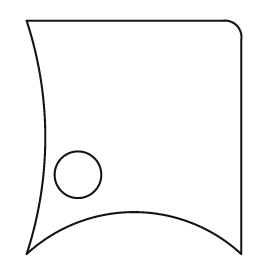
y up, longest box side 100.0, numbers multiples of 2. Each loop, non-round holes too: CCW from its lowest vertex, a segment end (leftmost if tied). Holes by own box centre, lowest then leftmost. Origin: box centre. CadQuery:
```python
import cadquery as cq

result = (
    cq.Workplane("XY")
    .moveTo(-46.0, -50.0)
    .threePointArc((0.0, -32.0), (46.0, -50.0))
    .lineTo(46.0, 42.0)
    .threePointArc((44.0, 48.0), (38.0, 50.0))
    .lineTo(-46.0, 50.0)
    .threePointArc((-38.0, 0.0), (-46.0, -50.0))
    .close()
    .moveTo(-24.0, -16.0)
    .circle(10.0)
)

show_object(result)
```